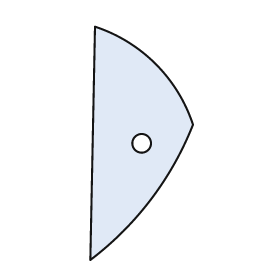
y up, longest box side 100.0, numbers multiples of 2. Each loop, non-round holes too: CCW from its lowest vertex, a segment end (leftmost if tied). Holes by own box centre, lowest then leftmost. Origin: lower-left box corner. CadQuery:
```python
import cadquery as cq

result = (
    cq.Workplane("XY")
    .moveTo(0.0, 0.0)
    .threePointArc((26.0, 26.0), (44.0, 58.0))
    .threePointArc((28.0, 84.0), (2.0, 100.0))
    .close()
    .moveTo(22.0, 50.0)
    .circle(4.0)
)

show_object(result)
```